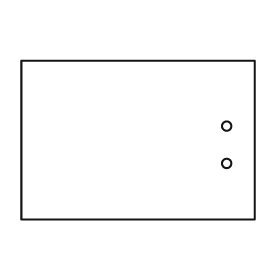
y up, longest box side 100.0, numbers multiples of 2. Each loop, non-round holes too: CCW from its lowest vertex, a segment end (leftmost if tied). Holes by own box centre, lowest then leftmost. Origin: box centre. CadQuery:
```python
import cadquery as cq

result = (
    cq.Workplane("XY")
    .moveTo(-50.0, -34.0)
    .lineTo(50.0, -34.0)
    .lineTo(50.0, 34.0)
    .lineTo(-50.0, 34.0)
    .close()
    .moveTo(38.0, -10.0)
    .circle(2.0)
    .moveTo(38.0, 6.0)
    .circle(2.0)
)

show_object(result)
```